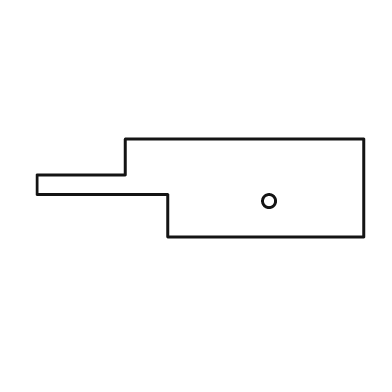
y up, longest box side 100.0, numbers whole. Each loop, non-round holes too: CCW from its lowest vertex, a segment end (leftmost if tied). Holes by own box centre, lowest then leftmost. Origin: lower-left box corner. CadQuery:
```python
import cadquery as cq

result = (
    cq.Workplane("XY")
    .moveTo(40.0, 0.0)
    .lineTo(100.0, 0.0)
    .lineTo(100.0, 30.0)
    .lineTo(27.0, 30.0)
    .lineTo(27.0, 19.0)
    .lineTo(0.0, 19.0)
    .lineTo(0.0, 13.0)
    .lineTo(40.0, 13.0)
    .close()
    .moveTo(71.0, 11.0)
    .circle(2.0)
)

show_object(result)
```